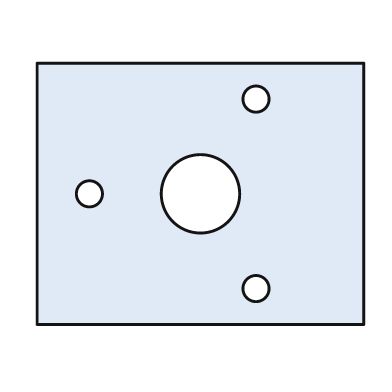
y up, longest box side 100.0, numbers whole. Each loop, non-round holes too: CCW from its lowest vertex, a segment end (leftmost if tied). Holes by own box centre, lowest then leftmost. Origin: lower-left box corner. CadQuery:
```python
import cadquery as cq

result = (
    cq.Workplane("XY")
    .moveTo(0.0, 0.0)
    .lineTo(100.0, 0.0)
    .lineTo(100.0, 80.0)
    .lineTo(0.0, 80.0)
    .close()
    .moveTo(67.0, 11.0)
    .circle(4.0)
    .moveTo(16.0, 40.0)
    .circle(4.0)
    .moveTo(50.0, 40.0)
    .circle(12.0)
    .moveTo(67.0, 69.0)
    .circle(4.0)
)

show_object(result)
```